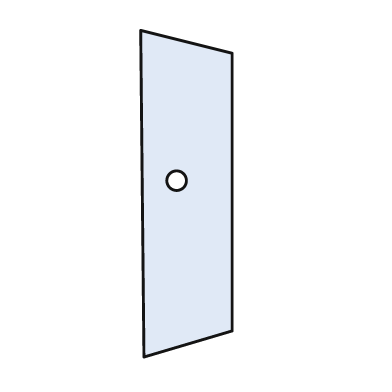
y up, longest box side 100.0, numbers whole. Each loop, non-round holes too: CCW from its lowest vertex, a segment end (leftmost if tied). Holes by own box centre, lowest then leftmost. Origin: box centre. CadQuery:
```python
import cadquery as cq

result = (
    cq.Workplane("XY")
    .moveTo(-13.0, -50.0)
    .lineTo(14.0, -42.0)
    .lineTo(14.0, 43.0)
    .lineTo(-14.0, 50.0)
    .close()
    .moveTo(-3.0, 4.0)
    .circle(3.0)
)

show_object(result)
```